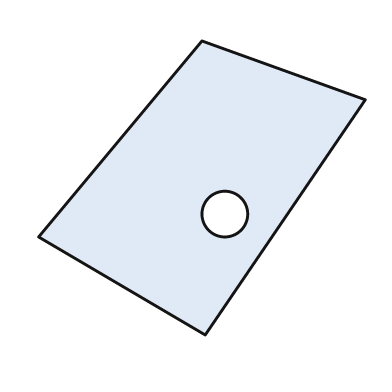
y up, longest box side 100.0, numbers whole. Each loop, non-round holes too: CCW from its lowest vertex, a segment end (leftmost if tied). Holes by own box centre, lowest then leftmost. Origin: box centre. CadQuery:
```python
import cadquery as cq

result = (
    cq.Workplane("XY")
    .moveTo(1.0, -45.0)
    .lineTo(50.0, 27.0)
    .lineTo(0.0, 45.0)
    .lineTo(-50.0, -15.0)
    .close()
    .moveTo(7.0, -8.0)
    .circle(7.0)
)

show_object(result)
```